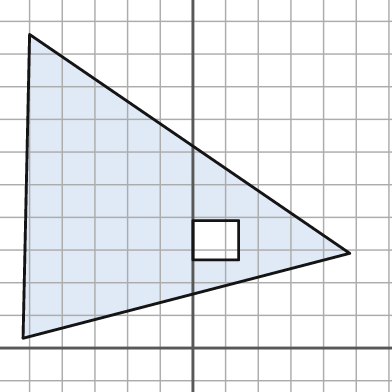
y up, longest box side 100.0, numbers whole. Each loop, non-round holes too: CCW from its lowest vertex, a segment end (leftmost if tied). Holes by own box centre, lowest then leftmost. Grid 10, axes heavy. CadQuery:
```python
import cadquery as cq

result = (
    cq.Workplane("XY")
    .moveTo(-52.0, 3.0)
    .lineTo(48.0, 29.0)
    .lineTo(-50.0, 96.0)
    .close()
    .moveTo(0.0, 27.0)
    .lineTo(14.0, 27.0)
    .lineTo(14.0, 39.0)
    .lineTo(0.0, 39.0)
    .close()
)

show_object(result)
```